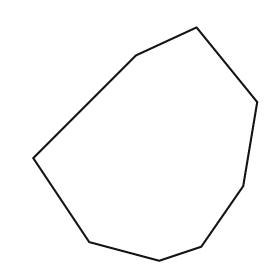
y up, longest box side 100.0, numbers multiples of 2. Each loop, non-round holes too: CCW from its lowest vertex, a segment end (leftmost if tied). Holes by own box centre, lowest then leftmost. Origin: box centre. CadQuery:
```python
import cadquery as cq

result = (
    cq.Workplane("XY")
    .moveTo(6.0, -50.0)
    .lineTo(24.0, -44.0)
    .lineTo(42.0, -18.0)
    .lineTo(48.0, 18.0)
    .lineTo(22.0, 50.0)
    .lineTo(-4.0, 38.0)
    .lineTo(-48.0, -6.0)
    .lineTo(-24.0, -42.0)
    .close()
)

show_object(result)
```